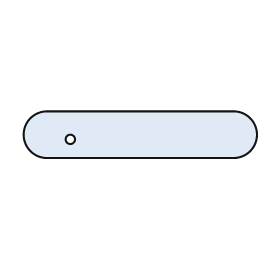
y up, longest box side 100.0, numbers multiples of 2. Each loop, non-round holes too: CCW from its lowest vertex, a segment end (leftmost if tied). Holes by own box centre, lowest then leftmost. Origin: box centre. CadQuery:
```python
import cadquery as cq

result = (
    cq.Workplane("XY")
    .moveTo(-40.0, -10.0)
    .lineTo(40.0, -10.0)
    .threePointArc((50.0, 0.0), (40.0, 10.0))
    .lineTo(-40.0, 10.0)
    .threePointArc((-50.0, 0.0), (-40.0, -10.0))
    .close()
    .moveTo(-30.0, -2.0)
    .circle(2.0)
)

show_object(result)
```